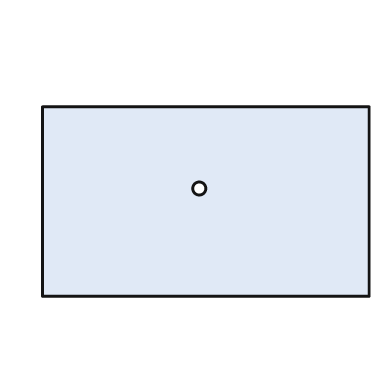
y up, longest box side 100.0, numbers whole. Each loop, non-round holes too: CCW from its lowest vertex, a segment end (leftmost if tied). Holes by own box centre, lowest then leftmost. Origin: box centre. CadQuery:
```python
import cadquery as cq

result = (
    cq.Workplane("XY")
    .moveTo(-50.0, -29.0)
    .lineTo(50.0, -29.0)
    .lineTo(50.0, 29.0)
    .lineTo(-50.0, 29.0)
    .close()
    .moveTo(-2.0, 4.0)
    .circle(2.0)
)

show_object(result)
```